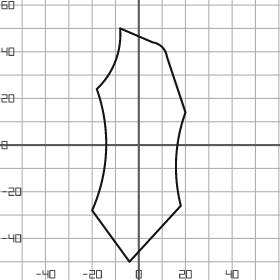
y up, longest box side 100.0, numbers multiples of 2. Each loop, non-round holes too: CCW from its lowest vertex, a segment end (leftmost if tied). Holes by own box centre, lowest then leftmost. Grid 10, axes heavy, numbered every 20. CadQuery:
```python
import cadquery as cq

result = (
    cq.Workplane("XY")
    .moveTo(-4.0, -50.0)
    .lineTo(18.0, -26.0)
    .threePointArc((16.0, -6.0), (20.0, 14.0))
    .lineTo(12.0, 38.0)
    .threePointArc((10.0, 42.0), (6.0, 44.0))
    .lineTo(-8.0, 50.0)
    .threePointArc((-10.0, 36.0), (-18.0, 24.0))
    .threePointArc((-14.0, -2.0), (-20.0, -28.0))
    .close()
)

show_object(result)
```